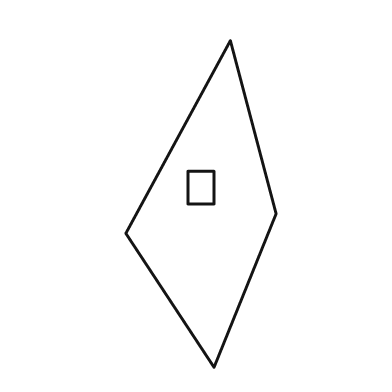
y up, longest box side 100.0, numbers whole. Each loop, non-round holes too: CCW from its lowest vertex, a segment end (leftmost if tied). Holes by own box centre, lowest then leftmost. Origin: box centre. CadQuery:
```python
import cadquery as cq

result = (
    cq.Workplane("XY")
    .moveTo(4.0, -50.0)
    .lineTo(23.0, -3.0)
    .lineTo(9.0, 50.0)
    .lineTo(-23.0, -9.0)
    .close()
    .moveTo(-4.0, 0.0)
    .lineTo(4.0, 0.0)
    .lineTo(4.0, 10.0)
    .lineTo(-4.0, 10.0)
    .close()
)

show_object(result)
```